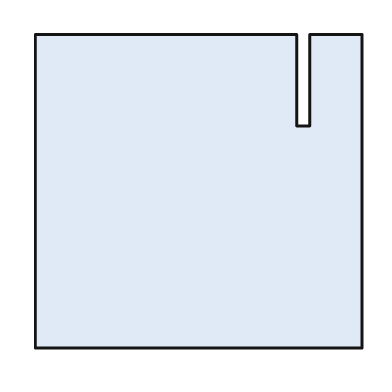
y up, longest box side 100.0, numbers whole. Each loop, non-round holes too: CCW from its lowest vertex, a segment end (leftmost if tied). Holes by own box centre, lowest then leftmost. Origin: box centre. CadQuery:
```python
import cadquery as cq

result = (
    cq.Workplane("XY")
    .moveTo(-50.0, -48.0)
    .lineTo(50.0, -48.0)
    .lineTo(50.0, 48.0)
    .lineTo(34.0, 48.0)
    .lineTo(34.0, 20.0)
    .lineTo(30.0, 20.0)
    .lineTo(30.0, 48.0)
    .lineTo(-50.0, 48.0)
    .close()
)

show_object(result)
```